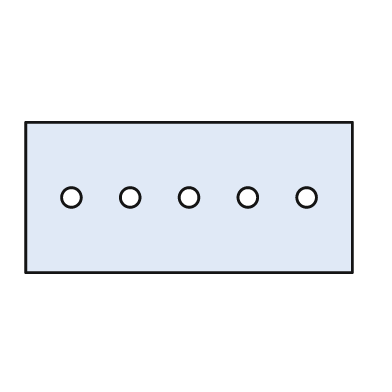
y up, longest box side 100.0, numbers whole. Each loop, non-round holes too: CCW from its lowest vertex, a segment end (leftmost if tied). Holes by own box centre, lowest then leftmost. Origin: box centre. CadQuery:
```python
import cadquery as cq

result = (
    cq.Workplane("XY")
    .moveTo(-50.0, -23.0)
    .lineTo(50.0, -23.0)
    .lineTo(50.0, 23.0)
    .lineTo(-50.0, 23.0)
    .close()
    .moveTo(-36.0, 0.0)
    .circle(3.0)
    .moveTo(-18.0, 0.0)
    .circle(3.0)
    .moveTo(0.0, 0.0)
    .circle(3.0)
    .moveTo(18.0, 0.0)
    .circle(3.0)
    .moveTo(36.0, 0.0)
    .circle(3.0)
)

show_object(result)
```